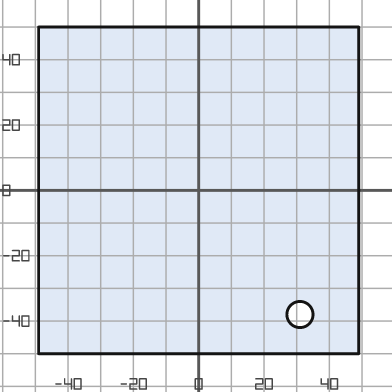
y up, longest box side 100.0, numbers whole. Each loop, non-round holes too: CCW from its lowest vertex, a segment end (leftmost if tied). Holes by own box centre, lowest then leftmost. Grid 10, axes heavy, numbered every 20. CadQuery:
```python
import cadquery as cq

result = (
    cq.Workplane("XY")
    .moveTo(-49.0, -50.0)
    .lineTo(49.0, -50.0)
    .lineTo(49.0, 50.0)
    .lineTo(-49.0, 50.0)
    .close()
    .moveTo(31.0, -38.0)
    .circle(4.0)
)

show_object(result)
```